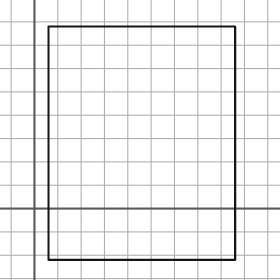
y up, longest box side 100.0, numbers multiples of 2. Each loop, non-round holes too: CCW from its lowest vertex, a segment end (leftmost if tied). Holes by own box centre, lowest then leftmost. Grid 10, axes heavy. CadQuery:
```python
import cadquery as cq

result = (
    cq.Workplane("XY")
    .moveTo(6.0, -22.0)
    .lineTo(86.0, -22.0)
    .lineTo(86.0, 78.0)
    .lineTo(6.0, 78.0)
    .close()
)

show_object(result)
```